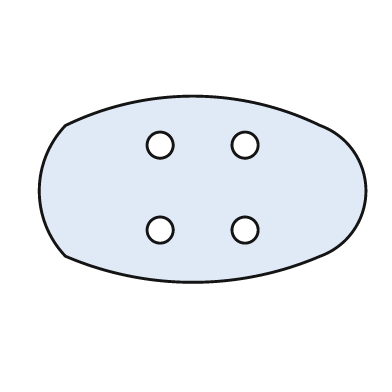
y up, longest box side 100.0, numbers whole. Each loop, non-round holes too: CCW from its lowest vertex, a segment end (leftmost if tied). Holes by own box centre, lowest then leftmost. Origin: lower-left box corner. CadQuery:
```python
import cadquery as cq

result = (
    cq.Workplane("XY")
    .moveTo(8.0, 8.0)
    .threePointArc((47.0, 0.0), (86.0, 8.0))
    .threePointArc((100.0, 28.0), (86.0, 48.0))
    .threePointArc((47.0, 57.0), (8.0, 48.0))
    .threePointArc((0.0, 28.0), (8.0, 8.0))
    .close()
    .moveTo(37.0, 16.0)
    .circle(4.0)
    .moveTo(63.0, 16.0)
    .circle(4.0)
    .moveTo(37.0, 42.0)
    .circle(4.0)
    .moveTo(63.0, 42.0)
    .circle(4.0)
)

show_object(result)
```